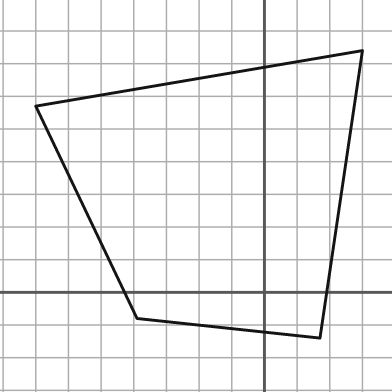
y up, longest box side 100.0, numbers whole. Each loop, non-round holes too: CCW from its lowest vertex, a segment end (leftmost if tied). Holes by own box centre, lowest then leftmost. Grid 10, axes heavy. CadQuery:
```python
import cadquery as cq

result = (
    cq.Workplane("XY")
    .moveTo(17.0, -14.0)
    .lineTo(30.0, 74.0)
    .lineTo(-70.0, 57.0)
    .lineTo(-39.0, -8.0)
    .close()
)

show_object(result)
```